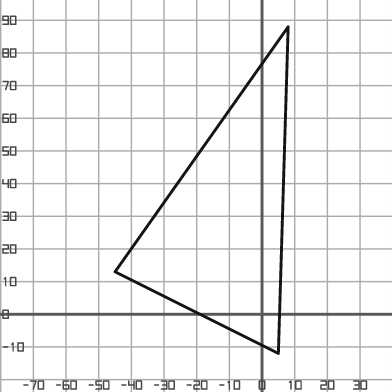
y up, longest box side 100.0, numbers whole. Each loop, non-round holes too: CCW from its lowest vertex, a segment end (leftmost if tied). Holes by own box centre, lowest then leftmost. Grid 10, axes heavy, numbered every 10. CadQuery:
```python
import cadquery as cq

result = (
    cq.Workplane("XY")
    .moveTo(5.0, -12.0)
    .lineTo(8.0, 88.0)
    .lineTo(-45.0, 13.0)
    .close()
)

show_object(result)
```